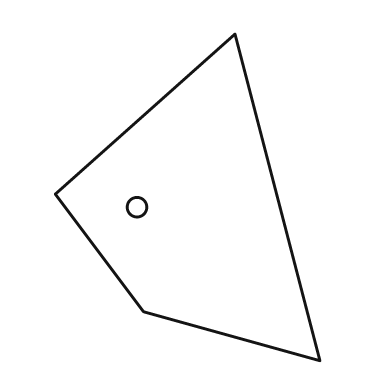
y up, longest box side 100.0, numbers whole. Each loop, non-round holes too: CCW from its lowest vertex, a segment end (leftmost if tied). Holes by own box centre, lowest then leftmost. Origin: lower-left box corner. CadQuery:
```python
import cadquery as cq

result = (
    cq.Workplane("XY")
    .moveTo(81.0, 0.0)
    .lineTo(55.0, 100.0)
    .lineTo(0.0, 51.0)
    .lineTo(27.0, 15.0)
    .close()
    .moveTo(25.0, 47.0)
    .circle(3.0)
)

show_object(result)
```